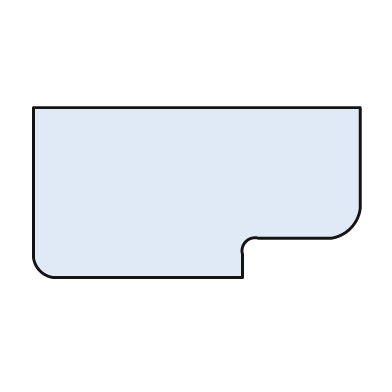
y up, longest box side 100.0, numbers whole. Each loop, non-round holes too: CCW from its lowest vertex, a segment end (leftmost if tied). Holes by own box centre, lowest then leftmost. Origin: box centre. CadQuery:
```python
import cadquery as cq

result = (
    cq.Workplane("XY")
    .moveTo(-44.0, -26.0)
    .lineTo(14.0, -26.0)
    .lineTo(14.0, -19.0)
    .threePointArc((15.0, -15.0), (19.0, -14.0))
    .lineTo(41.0, -14.0)
    .threePointArc((47.0, -11.0), (50.0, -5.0))
    .lineTo(50.0, 26.0)
    .lineTo(-50.0, 26.0)
    .lineTo(-50.0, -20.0)
    .threePointArc((-48.0, -24.0), (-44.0, -26.0))
    .close()
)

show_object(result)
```